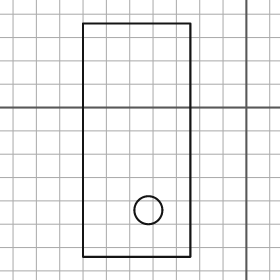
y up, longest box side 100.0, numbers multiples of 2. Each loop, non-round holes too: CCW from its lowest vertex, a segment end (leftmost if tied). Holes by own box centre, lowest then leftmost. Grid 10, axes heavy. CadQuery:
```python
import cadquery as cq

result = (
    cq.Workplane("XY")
    .moveTo(-70.0, -64.0)
    .lineTo(-24.0, -64.0)
    .lineTo(-24.0, 36.0)
    .lineTo(-70.0, 36.0)
    .close()
    .moveTo(-42.0, -44.0)
    .circle(6.0)
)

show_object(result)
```